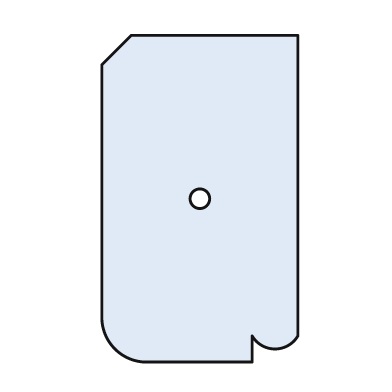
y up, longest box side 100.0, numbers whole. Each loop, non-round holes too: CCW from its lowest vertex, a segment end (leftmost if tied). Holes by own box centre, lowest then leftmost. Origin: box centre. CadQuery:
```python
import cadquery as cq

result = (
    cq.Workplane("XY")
    .moveTo(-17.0, -50.0)
    .lineTo(16.0, -50.0)
    .lineTo(16.0, -42.0)
    .threePointArc((23.0, -46.0), (30.0, -42.0))
    .lineTo(30.0, 50.0)
    .lineTo(-21.0, 50.0)
    .lineTo(-30.0, 41.0)
    .lineTo(-30.0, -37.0)
    .threePointArc((-26.0, -46.0), (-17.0, -50.0))
    .close()
    .moveTo(0.0, 0.0)
    .circle(3.0)
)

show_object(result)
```